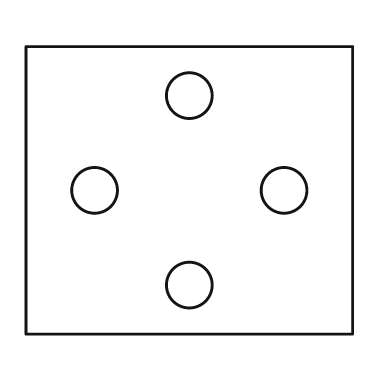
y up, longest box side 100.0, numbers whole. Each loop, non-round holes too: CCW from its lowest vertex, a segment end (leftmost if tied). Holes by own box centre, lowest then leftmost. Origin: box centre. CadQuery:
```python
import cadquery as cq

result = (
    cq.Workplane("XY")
    .moveTo(-50.0, -44.0)
    .lineTo(50.0, -44.0)
    .lineTo(50.0, 44.0)
    .lineTo(-50.0, 44.0)
    .close()
    .moveTo(0.0, -29.0)
    .circle(7.0)
    .moveTo(-29.0, 0.0)
    .circle(7.0)
    .moveTo(29.0, 0.0)
    .circle(7.0)
    .moveTo(0.0, 29.0)
    .circle(7.0)
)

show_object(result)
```